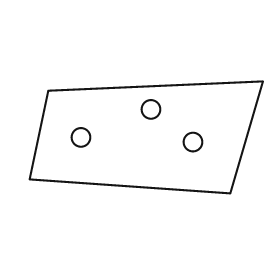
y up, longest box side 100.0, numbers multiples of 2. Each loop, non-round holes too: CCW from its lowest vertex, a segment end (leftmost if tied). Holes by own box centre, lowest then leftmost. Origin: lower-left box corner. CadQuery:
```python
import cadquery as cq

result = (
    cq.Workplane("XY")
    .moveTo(86.0, 0.0)
    .lineTo(100.0, 48.0)
    .lineTo(8.0, 44.0)
    .lineTo(0.0, 6.0)
    .close()
    .moveTo(70.0, 22.0)
    .circle(4.0)
    .moveTo(22.0, 24.0)
    .circle(4.0)
    .moveTo(52.0, 36.0)
    .circle(4.0)
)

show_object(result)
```